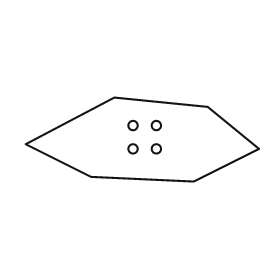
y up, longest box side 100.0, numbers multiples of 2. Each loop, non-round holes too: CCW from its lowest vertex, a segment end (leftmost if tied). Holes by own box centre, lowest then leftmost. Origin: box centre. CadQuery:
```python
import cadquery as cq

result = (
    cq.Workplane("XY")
    .moveTo(22.0, -18.0)
    .lineTo(50.0, -4.0)
    .lineTo(28.0, 14.0)
    .lineTo(-12.0, 18.0)
    .lineTo(-50.0, -2.0)
    .lineTo(-22.0, -16.0)
    .close()
    .moveTo(-4.0, -4.0)
    .circle(2.0)
    .moveTo(6.0, -4.0)
    .circle(2.0)
    .moveTo(-4.0, 6.0)
    .circle(2.0)
    .moveTo(6.0, 6.0)
    .circle(2.0)
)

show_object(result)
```